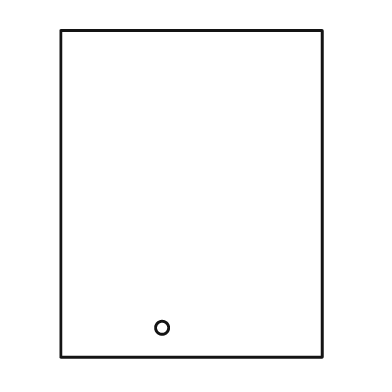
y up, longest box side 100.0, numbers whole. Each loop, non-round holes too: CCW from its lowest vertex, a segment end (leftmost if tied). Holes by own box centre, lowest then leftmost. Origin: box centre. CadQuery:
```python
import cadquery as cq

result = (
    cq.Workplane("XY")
    .moveTo(-40.0, -50.0)
    .lineTo(40.0, -50.0)
    .lineTo(40.0, 50.0)
    .lineTo(-40.0, 50.0)
    .close()
    .moveTo(-9.0, -41.0)
    .circle(2.0)
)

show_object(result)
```